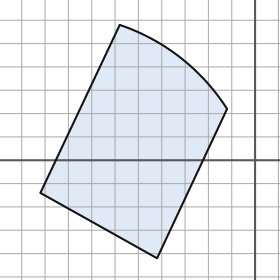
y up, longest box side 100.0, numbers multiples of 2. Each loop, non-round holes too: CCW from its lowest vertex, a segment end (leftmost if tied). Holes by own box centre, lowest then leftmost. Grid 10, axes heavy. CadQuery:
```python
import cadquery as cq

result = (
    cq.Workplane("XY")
    .moveTo(-42.0, -42.0)
    .lineTo(-12.0, 22.0)
    .threePointArc((-32.0, 44.0), (-58.0, 58.0))
    .lineTo(-92.0, -14.0)
    .close()
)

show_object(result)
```